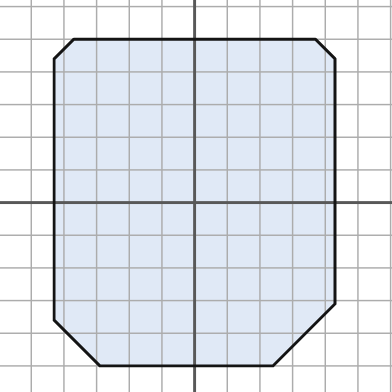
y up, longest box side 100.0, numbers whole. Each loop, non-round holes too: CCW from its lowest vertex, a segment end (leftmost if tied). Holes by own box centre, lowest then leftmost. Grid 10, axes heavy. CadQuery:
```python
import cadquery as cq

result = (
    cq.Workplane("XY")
    .moveTo(-29.0, -50.0)
    .lineTo(24.0, -50.0)
    .lineTo(43.0, -31.0)
    .lineTo(43.0, 44.0)
    .lineTo(37.0, 50.0)
    .lineTo(-37.0, 50.0)
    .lineTo(-43.0, 44.0)
    .lineTo(-43.0, -36.0)
    .close()
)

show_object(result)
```